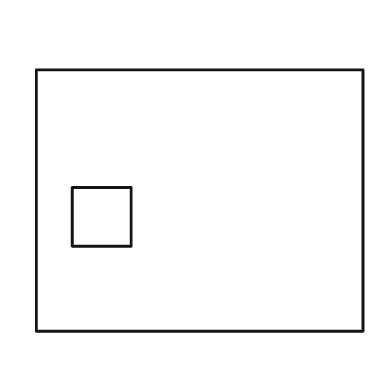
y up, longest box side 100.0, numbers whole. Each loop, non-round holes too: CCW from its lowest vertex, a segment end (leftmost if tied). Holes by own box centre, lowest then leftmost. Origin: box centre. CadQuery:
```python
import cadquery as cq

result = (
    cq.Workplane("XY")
    .moveTo(-50.0, -40.0)
    .lineTo(50.0, -40.0)
    .lineTo(50.0, 40.0)
    .lineTo(-50.0, 40.0)
    .close()
    .moveTo(-39.0, -14.0)
    .lineTo(-21.0, -14.0)
    .lineTo(-21.0, 4.0)
    .lineTo(-39.0, 4.0)
    .close()
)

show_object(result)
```